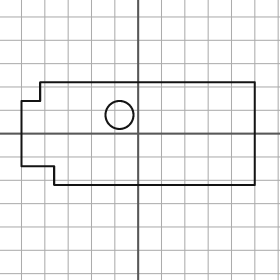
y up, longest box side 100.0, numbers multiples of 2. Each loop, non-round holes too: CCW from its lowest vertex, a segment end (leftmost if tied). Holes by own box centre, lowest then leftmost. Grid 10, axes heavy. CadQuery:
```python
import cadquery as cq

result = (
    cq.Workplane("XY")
    .moveTo(-36.0, -22.0)
    .lineTo(50.0, -22.0)
    .lineTo(50.0, 22.0)
    .lineTo(-42.0, 22.0)
    .lineTo(-42.0, 14.0)
    .lineTo(-50.0, 14.0)
    .lineTo(-50.0, -14.0)
    .lineTo(-36.0, -14.0)
    .close()
    .moveTo(-8.0, 8.0)
    .circle(6.0)
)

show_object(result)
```